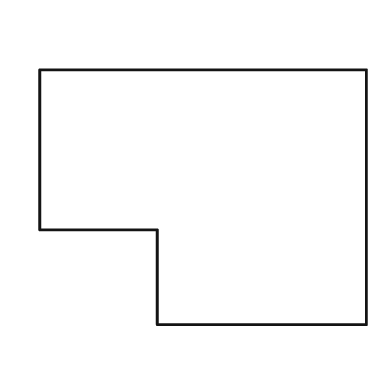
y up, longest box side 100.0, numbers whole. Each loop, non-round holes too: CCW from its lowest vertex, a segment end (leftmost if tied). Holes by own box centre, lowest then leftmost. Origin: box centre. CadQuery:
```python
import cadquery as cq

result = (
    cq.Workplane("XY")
    .moveTo(-14.0, -39.0)
    .lineTo(50.0, -39.0)
    .lineTo(50.0, 39.0)
    .lineTo(-50.0, 39.0)
    .lineTo(-50.0, -10.0)
    .lineTo(-14.0, -10.0)
    .close()
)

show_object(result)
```